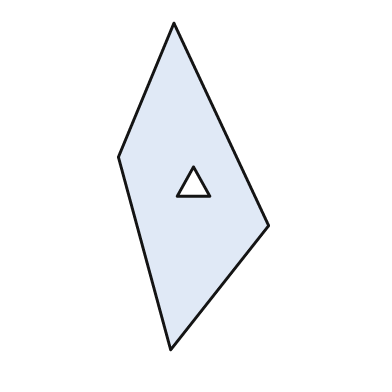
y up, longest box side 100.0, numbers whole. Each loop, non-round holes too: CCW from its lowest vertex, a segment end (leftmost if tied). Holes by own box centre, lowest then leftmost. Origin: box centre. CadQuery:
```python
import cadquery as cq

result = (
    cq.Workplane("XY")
    .moveTo(-7.0, -50.0)
    .lineTo(23.0, -12.0)
    .lineTo(-6.0, 50.0)
    .lineTo(-23.0, 9.0)
    .close()
    .moveTo(-5.0, -3.0)
    .lineTo(5.0, -3.0)
    .lineTo(0.0, 6.0)
    .close()
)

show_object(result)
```